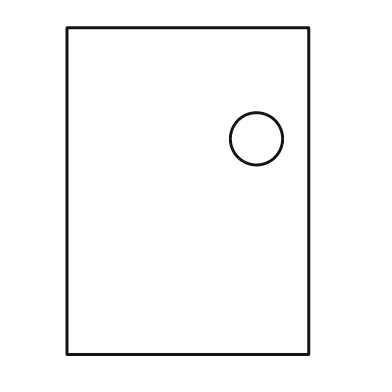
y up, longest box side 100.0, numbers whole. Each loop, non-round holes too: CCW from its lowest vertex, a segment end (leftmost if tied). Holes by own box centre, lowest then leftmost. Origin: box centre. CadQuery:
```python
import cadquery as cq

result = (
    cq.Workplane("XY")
    .moveTo(-37.0, -50.0)
    .lineTo(37.0, -50.0)
    .lineTo(37.0, 50.0)
    .lineTo(-37.0, 50.0)
    .close()
    .moveTo(21.0, 16.0)
    .circle(8.0)
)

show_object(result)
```